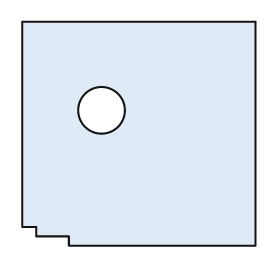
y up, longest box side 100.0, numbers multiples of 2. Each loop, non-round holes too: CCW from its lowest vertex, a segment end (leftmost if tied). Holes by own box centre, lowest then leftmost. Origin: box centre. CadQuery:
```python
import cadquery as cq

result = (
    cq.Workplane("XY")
    .moveTo(-30.0, -48.0)
    .lineTo(50.0, -48.0)
    .lineTo(50.0, 48.0)
    .lineTo(-50.0, 48.0)
    .lineTo(-50.0, -40.0)
    .lineTo(-44.0, -40.0)
    .lineTo(-44.0, -44.0)
    .lineTo(-30.0, -44.0)
    .close()
    .moveTo(-16.0, 10.0)
    .circle(10.0)
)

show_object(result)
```